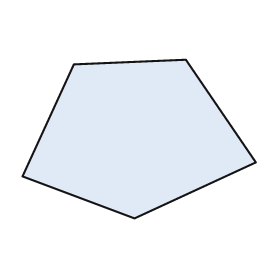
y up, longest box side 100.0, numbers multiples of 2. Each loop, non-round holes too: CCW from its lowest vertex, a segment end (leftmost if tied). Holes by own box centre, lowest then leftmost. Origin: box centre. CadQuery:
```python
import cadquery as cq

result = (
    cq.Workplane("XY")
    .moveTo(-2.0, -34.0)
    .lineTo(50.0, -10.0)
    .lineTo(20.0, 34.0)
    .lineTo(-28.0, 32.0)
    .lineTo(-50.0, -16.0)
    .close()
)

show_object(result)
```